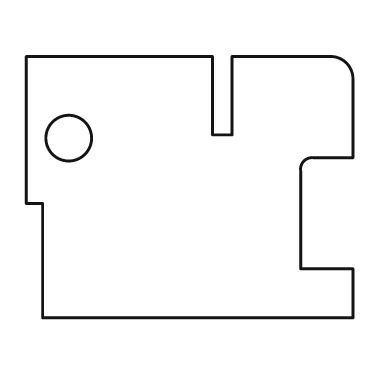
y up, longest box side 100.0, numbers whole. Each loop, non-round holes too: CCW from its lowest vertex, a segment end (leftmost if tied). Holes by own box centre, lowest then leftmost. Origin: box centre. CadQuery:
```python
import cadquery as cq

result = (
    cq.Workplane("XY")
    .moveTo(-45.0, -40.0)
    .lineTo(50.0, -40.0)
    .lineTo(50.0, -25.0)
    .lineTo(34.0, -25.0)
    .lineTo(34.0, 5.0)
    .threePointArc((35.0, 8.0), (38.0, 9.0))
    .lineTo(50.0, 9.0)
    .lineTo(50.0, 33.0)
    .threePointArc((48.0, 38.0), (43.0, 40.0))
    .lineTo(13.0, 40.0)
    .lineTo(13.0, 16.0)
    .lineTo(7.0, 16.0)
    .lineTo(7.0, 40.0)
    .lineTo(-50.0, 40.0)
    .lineTo(-50.0, -5.0)
    .lineTo(-45.0, -5.0)
    .close()
    .moveTo(-37.0, 15.0)
    .circle(7.0)
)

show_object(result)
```